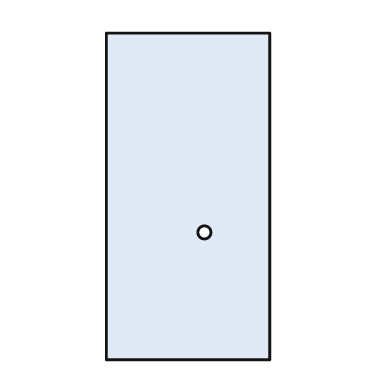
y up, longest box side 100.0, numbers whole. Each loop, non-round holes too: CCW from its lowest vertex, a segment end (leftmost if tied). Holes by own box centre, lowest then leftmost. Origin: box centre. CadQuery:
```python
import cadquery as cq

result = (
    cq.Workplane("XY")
    .moveTo(-25.0, -50.0)
    .lineTo(25.0, -50.0)
    .lineTo(25.0, 50.0)
    .lineTo(-25.0, 50.0)
    .close()
    .moveTo(5.0, -11.0)
    .circle(2.0)
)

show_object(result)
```